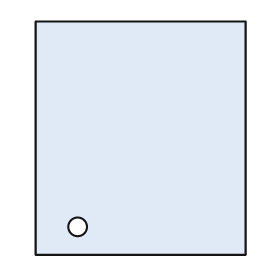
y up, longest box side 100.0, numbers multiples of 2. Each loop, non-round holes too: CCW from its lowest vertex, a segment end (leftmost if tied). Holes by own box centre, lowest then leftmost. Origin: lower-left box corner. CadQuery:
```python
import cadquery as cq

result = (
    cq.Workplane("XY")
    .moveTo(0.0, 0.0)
    .lineTo(90.0, 0.0)
    .lineTo(90.0, 100.0)
    .lineTo(0.0, 100.0)
    .close()
    .moveTo(18.0, 12.0)
    .circle(4.0)
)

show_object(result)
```